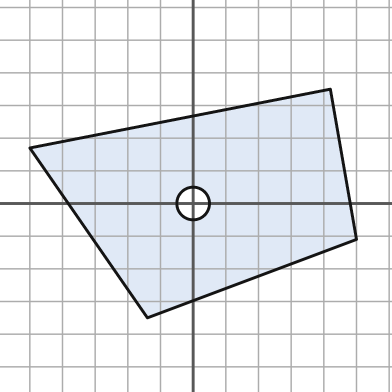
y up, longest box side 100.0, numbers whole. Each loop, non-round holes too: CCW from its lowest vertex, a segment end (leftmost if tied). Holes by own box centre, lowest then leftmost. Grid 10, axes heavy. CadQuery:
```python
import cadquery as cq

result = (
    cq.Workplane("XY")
    .moveTo(-14.0, -35.0)
    .lineTo(50.0, -11.0)
    .lineTo(42.0, 35.0)
    .lineTo(-50.0, 17.0)
    .close()
    .moveTo(0.0, 0.0)
    .circle(5.0)
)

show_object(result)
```